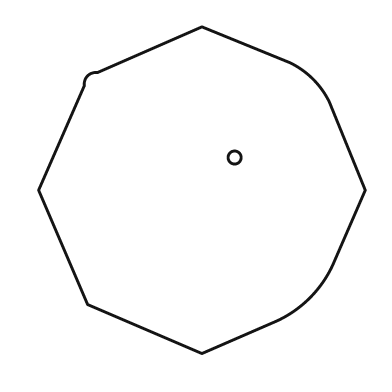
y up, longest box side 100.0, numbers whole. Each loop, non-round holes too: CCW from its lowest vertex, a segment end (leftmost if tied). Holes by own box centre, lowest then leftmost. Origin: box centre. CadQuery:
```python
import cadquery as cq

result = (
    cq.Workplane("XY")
    .moveTo(0.0, -50.0)
    .lineTo(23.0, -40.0)
    .threePointArc((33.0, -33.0), (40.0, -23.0))
    .lineTo(50.0, 0.0)
    .lineTo(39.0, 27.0)
    .threePointArc((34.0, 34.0), (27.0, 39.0))
    .lineTo(0.0, 50.0)
    .lineTo(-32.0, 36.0)
    .threePointArc((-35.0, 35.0), (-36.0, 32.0))
    .lineTo(-50.0, 0.0)
    .lineTo(-35.0, -35.0)
    .close()
    .moveTo(10.0, 10.0)
    .circle(2.0)
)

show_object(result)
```